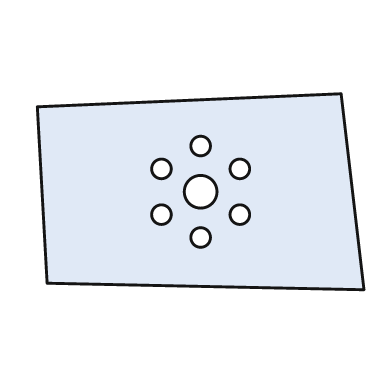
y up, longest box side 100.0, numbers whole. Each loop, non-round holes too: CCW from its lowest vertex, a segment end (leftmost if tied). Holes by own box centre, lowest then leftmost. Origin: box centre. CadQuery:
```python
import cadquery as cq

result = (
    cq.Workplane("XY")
    .moveTo(50.0, -30.0)
    .lineTo(43.0, 30.0)
    .lineTo(-50.0, 26.0)
    .lineTo(-47.0, -28.0)
    .close()
    .moveTo(0.0, -14.0)
    .circle(3.0)
    .moveTo(-12.0, -7.0)
    .circle(3.0)
    .moveTo(12.0, -7.0)
    .circle(3.0)
    .moveTo(0.0, 0.0)
    .circle(5.0)
    .moveTo(-12.0, 7.0)
    .circle(3.0)
    .moveTo(12.0, 7.0)
    .circle(3.0)
    .moveTo(0.0, 14.0)
    .circle(3.0)
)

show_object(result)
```